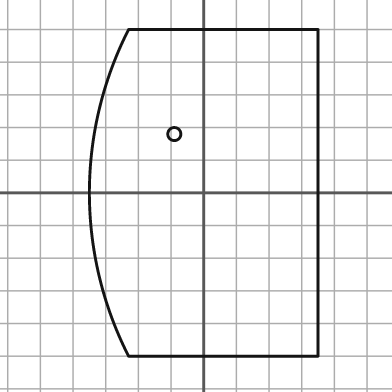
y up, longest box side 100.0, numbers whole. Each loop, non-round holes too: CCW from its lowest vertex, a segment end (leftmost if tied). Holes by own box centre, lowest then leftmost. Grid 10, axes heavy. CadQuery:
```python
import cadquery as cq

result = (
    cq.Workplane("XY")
    .moveTo(-23.0, -50.0)
    .lineTo(35.0, -50.0)
    .lineTo(35.0, 50.0)
    .lineTo(-23.0, 50.0)
    .threePointArc((-35.0, 0.0), (-23.0, -50.0))
    .close()
    .moveTo(-9.0, 18.0)
    .circle(2.0)
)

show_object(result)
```